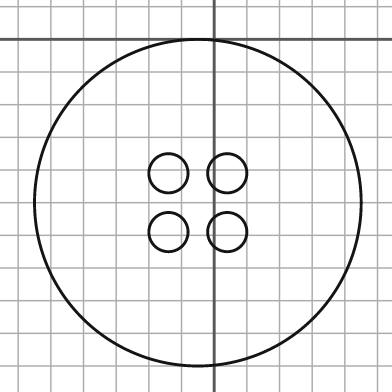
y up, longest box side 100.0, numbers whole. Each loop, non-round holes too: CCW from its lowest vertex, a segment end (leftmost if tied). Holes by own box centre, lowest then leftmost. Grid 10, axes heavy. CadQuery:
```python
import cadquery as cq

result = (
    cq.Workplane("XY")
    .moveTo(-5.0, -50.0)
    .circle(50.0)
    .moveTo(-14.0, -59.0)
    .circle(6.0)
    .moveTo(4.0, -59.0)
    .circle(6.0)
    .moveTo(-14.0, -41.0)
    .circle(6.0)
    .moveTo(4.0, -41.0)
    .circle(6.0)
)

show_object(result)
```